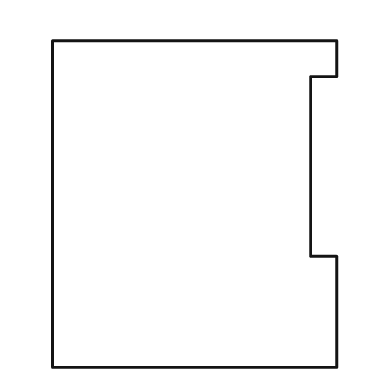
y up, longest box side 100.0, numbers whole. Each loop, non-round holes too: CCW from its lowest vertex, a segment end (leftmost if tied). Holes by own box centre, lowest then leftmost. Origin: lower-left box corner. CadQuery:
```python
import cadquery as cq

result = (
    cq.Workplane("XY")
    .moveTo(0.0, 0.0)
    .lineTo(87.0, 0.0)
    .lineTo(87.0, 34.0)
    .lineTo(79.0, 34.0)
    .lineTo(79.0, 89.0)
    .lineTo(87.0, 89.0)
    .lineTo(87.0, 100.0)
    .lineTo(0.0, 100.0)
    .close()
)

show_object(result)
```